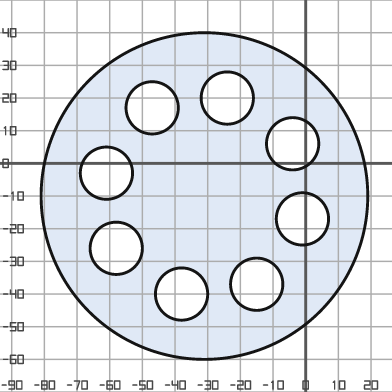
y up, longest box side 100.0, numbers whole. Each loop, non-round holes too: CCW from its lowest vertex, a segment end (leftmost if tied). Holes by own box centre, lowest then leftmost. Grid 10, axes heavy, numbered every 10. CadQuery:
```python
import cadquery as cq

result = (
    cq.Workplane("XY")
    .moveTo(-31.0, -10.0)
    .circle(50.0)
    .moveTo(-38.0, -40.0)
    .circle(8.0)
    .moveTo(-15.0, -37.0)
    .circle(8.0)
    .moveTo(-58.0, -26.0)
    .circle(8.0)
    .moveTo(-1.0, -17.0)
    .circle(8.0)
    .moveTo(-61.0, -3.0)
    .circle(8.0)
    .moveTo(-4.0, 6.0)
    .circle(8.0)
    .moveTo(-47.0, 17.0)
    .circle(8.0)
    .moveTo(-24.0, 20.0)
    .circle(8.0)
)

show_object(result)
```